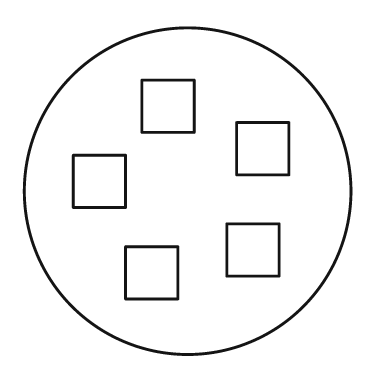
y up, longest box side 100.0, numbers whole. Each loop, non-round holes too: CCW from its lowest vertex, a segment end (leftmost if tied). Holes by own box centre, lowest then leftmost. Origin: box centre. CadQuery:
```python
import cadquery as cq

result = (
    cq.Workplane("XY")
    .moveTo(0.0, 0.0)
    .circle(50.0)
    .moveTo(-19.0, -33.0)
    .lineTo(-3.0, -33.0)
    .lineTo(-3.0, -17.0)
    .lineTo(-19.0, -17.0)
    .close()
    .moveTo(12.0, -26.0)
    .lineTo(28.0, -26.0)
    .lineTo(28.0, -10.0)
    .lineTo(12.0, -10.0)
    .close()
    .moveTo(-35.0, -5.0)
    .lineTo(-19.0, -5.0)
    .lineTo(-19.0, 11.0)
    .lineTo(-35.0, 11.0)
    .close()
    .moveTo(15.0, 5.0)
    .lineTo(31.0, 5.0)
    .lineTo(31.0, 21.0)
    .lineTo(15.0, 21.0)
    .close()
    .moveTo(-14.0, 18.0)
    .lineTo(2.0, 18.0)
    .lineTo(2.0, 34.0)
    .lineTo(-14.0, 34.0)
    .close()
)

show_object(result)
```